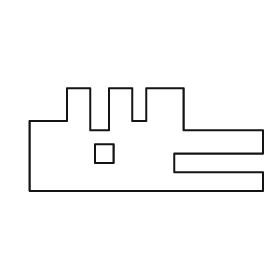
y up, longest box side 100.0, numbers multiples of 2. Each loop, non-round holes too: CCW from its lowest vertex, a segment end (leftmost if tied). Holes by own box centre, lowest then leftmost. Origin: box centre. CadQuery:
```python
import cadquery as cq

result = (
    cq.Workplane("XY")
    .moveTo(-50.0, -22.0)
    .lineTo(50.0, -22.0)
    .lineTo(50.0, -14.0)
    .lineTo(12.0, -14.0)
    .lineTo(12.0, -6.0)
    .lineTo(50.0, -6.0)
    .lineTo(50.0, 4.0)
    .lineTo(16.0, 4.0)
    .lineTo(16.0, 22.0)
    .lineTo(0.0, 22.0)
    .lineTo(0.0, 8.0)
    .lineTo(-6.0, 8.0)
    .lineTo(-6.0, 22.0)
    .lineTo(-16.0, 22.0)
    .lineTo(-16.0, 4.0)
    .lineTo(-24.0, 4.0)
    .lineTo(-24.0, 22.0)
    .lineTo(-34.0, 22.0)
    .lineTo(-34.0, 8.0)
    .lineTo(-50.0, 8.0)
    .close()
    .moveTo(-22.0, -10.0)
    .lineTo(-14.0, -10.0)
    .lineTo(-14.0, -2.0)
    .lineTo(-22.0, -2.0)
    .close()
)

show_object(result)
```